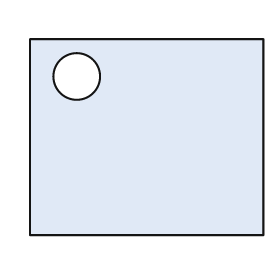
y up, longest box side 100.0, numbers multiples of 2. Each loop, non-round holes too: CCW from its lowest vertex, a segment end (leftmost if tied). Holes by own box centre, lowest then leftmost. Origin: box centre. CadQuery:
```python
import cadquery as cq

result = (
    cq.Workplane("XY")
    .moveTo(-50.0, -42.0)
    .lineTo(50.0, -42.0)
    .lineTo(50.0, 42.0)
    .lineTo(-50.0, 42.0)
    .close()
    .moveTo(-30.0, 26.0)
    .circle(10.0)
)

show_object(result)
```